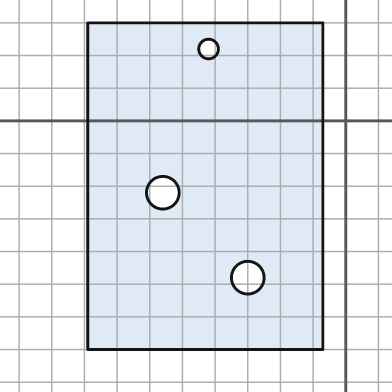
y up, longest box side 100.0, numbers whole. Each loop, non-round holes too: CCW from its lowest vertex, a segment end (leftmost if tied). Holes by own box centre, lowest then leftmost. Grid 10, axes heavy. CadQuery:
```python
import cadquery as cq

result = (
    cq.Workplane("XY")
    .moveTo(-79.0, -70.0)
    .lineTo(-7.0, -70.0)
    .lineTo(-7.0, 30.0)
    .lineTo(-79.0, 30.0)
    .close()
    .moveTo(-30.0, -48.0)
    .circle(5.0)
    .moveTo(-56.0, -22.0)
    .circle(5.0)
    .moveTo(-42.0, 22.0)
    .circle(3.0)
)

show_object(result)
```